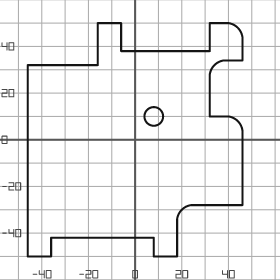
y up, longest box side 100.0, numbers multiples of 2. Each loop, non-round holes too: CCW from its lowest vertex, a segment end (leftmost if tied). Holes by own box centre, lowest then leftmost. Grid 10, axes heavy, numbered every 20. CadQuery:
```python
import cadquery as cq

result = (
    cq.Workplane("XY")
    .moveTo(-46.0, -50.0)
    .lineTo(-36.0, -50.0)
    .lineTo(-36.0, -42.0)
    .lineTo(8.0, -42.0)
    .lineTo(8.0, -50.0)
    .lineTo(18.0, -50.0)
    .lineTo(18.0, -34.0)
    .threePointArc((20.0, -30.0), (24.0, -28.0))
    .lineTo(46.0, -28.0)
    .lineTo(46.0, 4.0)
    .threePointArc((44.0, 8.0), (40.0, 10.0))
    .lineTo(32.0, 10.0)
    .lineTo(32.0, 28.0)
    .threePointArc((34.0, 32.0), (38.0, 34.0))
    .lineTo(46.0, 34.0)
    .lineTo(46.0, 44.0)
    .threePointArc((44.0, 48.0), (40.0, 50.0))
    .lineTo(32.0, 50.0)
    .lineTo(32.0, 38.0)
    .lineTo(-6.0, 38.0)
    .lineTo(-6.0, 50.0)
    .lineTo(-16.0, 50.0)
    .lineTo(-16.0, 32.0)
    .lineTo(-46.0, 32.0)
    .close()
    .moveTo(8.0, 10.0)
    .circle(4.0)
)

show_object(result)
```